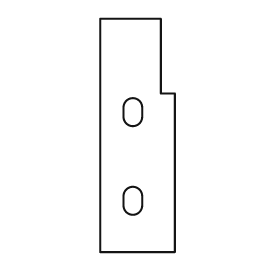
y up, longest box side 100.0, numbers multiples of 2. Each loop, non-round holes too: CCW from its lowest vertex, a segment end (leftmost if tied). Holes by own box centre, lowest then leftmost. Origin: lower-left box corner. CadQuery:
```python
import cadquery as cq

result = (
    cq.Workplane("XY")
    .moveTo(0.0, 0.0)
    .lineTo(32.0, 0.0)
    .lineTo(32.0, 68.0)
    .lineTo(26.0, 68.0)
    .lineTo(26.0, 100.0)
    .lineTo(0.0, 100.0)
    .close()
    .moveTo(10.0, 20.0)
    .threePointArc((14.0, 16.0), (18.0, 20.0))
    .lineTo(18.0, 24.0)
    .threePointArc((14.0, 28.0), (10.0, 24.0))
    .close()
    .moveTo(10.0, 58.0)
    .threePointArc((14.0, 54.0), (18.0, 58.0))
    .lineTo(18.0, 62.0)
    .threePointArc((14.0, 66.0), (10.0, 62.0))
    .close()
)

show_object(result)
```